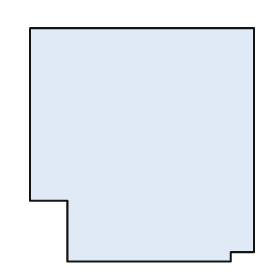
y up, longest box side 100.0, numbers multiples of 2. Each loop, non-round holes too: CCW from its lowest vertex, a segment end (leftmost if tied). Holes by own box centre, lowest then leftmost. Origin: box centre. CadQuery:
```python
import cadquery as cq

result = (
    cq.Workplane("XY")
    .moveTo(-32.0, -50.0)
    .lineTo(38.0, -50.0)
    .lineTo(38.0, -46.0)
    .lineTo(48.0, -46.0)
    .lineTo(48.0, 50.0)
    .lineTo(-48.0, 50.0)
    .lineTo(-48.0, -24.0)
    .lineTo(-32.0, -24.0)
    .close()
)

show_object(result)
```